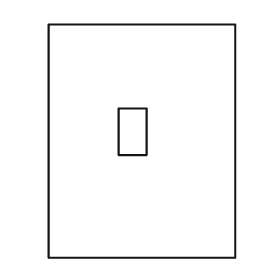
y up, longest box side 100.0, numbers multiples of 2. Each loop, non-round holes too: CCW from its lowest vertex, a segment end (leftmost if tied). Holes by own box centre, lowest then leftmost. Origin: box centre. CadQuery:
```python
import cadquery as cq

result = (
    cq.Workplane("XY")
    .moveTo(-40.0, -50.0)
    .lineTo(40.0, -50.0)
    .lineTo(40.0, 50.0)
    .lineTo(-40.0, 50.0)
    .close()
    .moveTo(-10.0, -6.0)
    .lineTo(2.0, -6.0)
    .lineTo(2.0, 14.0)
    .lineTo(-10.0, 14.0)
    .close()
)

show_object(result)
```